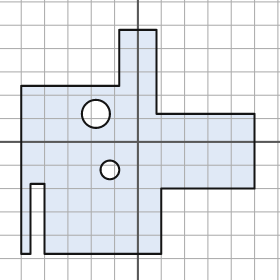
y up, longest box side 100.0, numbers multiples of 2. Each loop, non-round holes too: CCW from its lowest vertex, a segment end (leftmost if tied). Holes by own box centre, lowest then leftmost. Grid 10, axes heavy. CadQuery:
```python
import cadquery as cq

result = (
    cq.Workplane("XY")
    .moveTo(-50.0, -48.0)
    .lineTo(-46.0, -48.0)
    .lineTo(-46.0, -18.0)
    .lineTo(-40.0, -18.0)
    .lineTo(-40.0, -48.0)
    .lineTo(10.0, -48.0)
    .lineTo(10.0, -20.0)
    .lineTo(50.0, -20.0)
    .lineTo(50.0, 12.0)
    .lineTo(8.0, 12.0)
    .lineTo(8.0, 48.0)
    .lineTo(-8.0, 48.0)
    .lineTo(-8.0, 24.0)
    .lineTo(-50.0, 24.0)
    .close()
    .moveTo(-12.0, -12.0)
    .circle(4.0)
    .moveTo(-18.0, 12.0)
    .circle(6.0)
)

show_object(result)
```